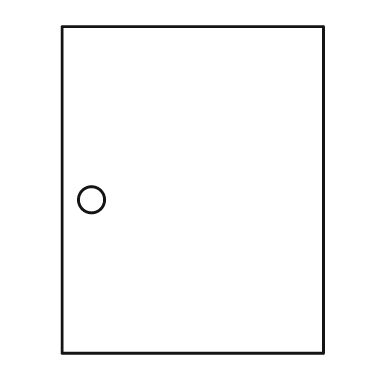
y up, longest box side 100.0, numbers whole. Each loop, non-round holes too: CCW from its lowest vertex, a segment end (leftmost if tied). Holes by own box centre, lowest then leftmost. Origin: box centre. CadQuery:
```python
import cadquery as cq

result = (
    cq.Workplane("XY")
    .moveTo(-40.0, -50.0)
    .lineTo(40.0, -50.0)
    .lineTo(40.0, 50.0)
    .lineTo(-40.0, 50.0)
    .close()
    .moveTo(-31.0, -3.0)
    .circle(4.0)
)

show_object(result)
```